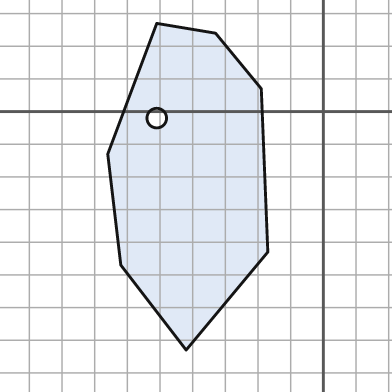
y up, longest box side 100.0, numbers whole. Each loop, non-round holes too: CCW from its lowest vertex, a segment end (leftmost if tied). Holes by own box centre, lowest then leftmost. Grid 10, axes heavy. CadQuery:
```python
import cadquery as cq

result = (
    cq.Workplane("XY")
    .moveTo(-42.0, -73.0)
    .lineTo(-17.0, -43.0)
    .lineTo(-19.0, 7.0)
    .lineTo(-33.0, 24.0)
    .lineTo(-51.0, 27.0)
    .lineTo(-66.0, -13.0)
    .lineTo(-62.0, -47.0)
    .close()
    .moveTo(-51.0, -2.0)
    .circle(3.0)
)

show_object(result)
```